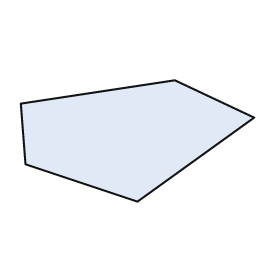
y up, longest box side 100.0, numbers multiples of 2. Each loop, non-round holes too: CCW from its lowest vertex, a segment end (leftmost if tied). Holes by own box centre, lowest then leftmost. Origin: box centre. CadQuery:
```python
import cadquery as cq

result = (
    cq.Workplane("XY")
    .moveTo(0.0, -26.0)
    .lineTo(50.0, 10.0)
    .lineTo(16.0, 26.0)
    .lineTo(-50.0, 16.0)
    .lineTo(-48.0, -10.0)
    .close()
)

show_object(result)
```